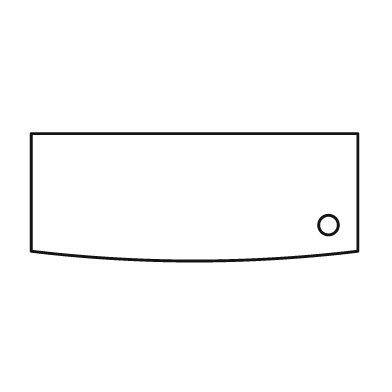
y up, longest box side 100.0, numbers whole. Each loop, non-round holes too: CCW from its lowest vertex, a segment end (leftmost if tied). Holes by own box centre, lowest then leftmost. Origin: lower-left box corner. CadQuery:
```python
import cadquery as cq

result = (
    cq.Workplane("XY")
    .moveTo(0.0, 3.0)
    .threePointArc((50.0, 0.0), (100.0, 3.0))
    .lineTo(100.0, 39.0)
    .lineTo(0.0, 39.0)
    .close()
    .moveTo(91.0, 11.0)
    .circle(3.0)
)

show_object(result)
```